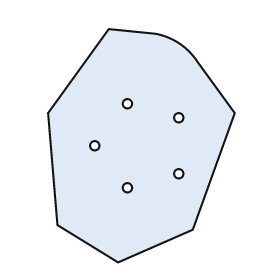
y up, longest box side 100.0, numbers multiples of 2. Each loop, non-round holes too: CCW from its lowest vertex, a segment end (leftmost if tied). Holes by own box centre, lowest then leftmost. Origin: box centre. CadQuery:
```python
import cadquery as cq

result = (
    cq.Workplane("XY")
    .moveTo(-10.0, -50.0)
    .lineTo(22.0, -36.0)
    .lineTo(40.0, 14.0)
    .lineTo(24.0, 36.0)
    .threePointArc((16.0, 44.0), (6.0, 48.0))
    .lineTo(-14.0, 50.0)
    .lineTo(-40.0, 14.0)
    .lineTo(-36.0, -34.0)
    .close()
    .moveTo(-6.0, -18.0)
    .circle(2.0)
    .moveTo(16.0, -12.0)
    .circle(2.0)
    .moveTo(-20.0, 0.0)
    .circle(2.0)
    .moveTo(16.0, 12.0)
    .circle(2.0)
    .moveTo(-6.0, 18.0)
    .circle(2.0)
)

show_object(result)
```